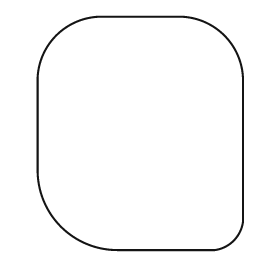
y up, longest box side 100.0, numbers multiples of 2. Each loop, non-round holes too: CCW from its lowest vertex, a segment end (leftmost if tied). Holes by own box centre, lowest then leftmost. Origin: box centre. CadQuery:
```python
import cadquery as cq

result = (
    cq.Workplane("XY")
    .moveTo(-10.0, -50.0)
    .lineTo(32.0, -50.0)
    .threePointArc((40.0, -46.0), (44.0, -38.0))
    .lineTo(44.0, 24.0)
    .threePointArc((36.0, 42.0), (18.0, 50.0))
    .lineTo(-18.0, 50.0)
    .threePointArc((-36.0, 42.0), (-44.0, 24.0))
    .lineTo(-44.0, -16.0)
    .threePointArc((-34.0, -40.0), (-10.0, -50.0))
    .close()
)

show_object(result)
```